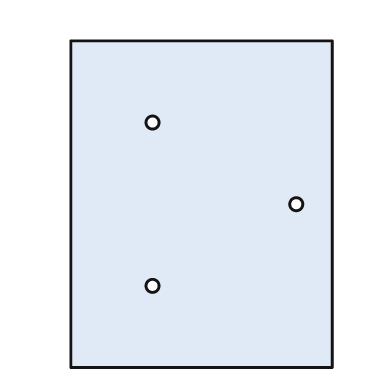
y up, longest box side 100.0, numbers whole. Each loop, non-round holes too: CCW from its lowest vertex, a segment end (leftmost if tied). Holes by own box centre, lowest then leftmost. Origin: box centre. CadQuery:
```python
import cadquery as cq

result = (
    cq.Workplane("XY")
    .moveTo(-40.0, -50.0)
    .lineTo(40.0, -50.0)
    .lineTo(40.0, 50.0)
    .lineTo(-40.0, 50.0)
    .close()
    .moveTo(-15.0, -25.0)
    .circle(2.0)
    .moveTo(29.0, 0.0)
    .circle(2.0)
    .moveTo(-15.0, 25.0)
    .circle(2.0)
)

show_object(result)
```